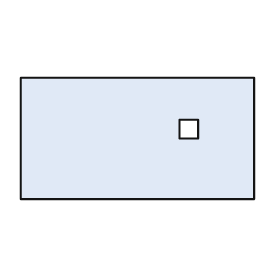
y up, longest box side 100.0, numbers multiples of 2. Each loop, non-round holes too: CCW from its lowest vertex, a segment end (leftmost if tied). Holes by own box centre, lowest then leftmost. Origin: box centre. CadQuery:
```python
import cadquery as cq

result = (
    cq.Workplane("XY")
    .moveTo(-50.0, -26.0)
    .lineTo(50.0, -26.0)
    .lineTo(50.0, 26.0)
    .lineTo(-50.0, 26.0)
    .close()
    .moveTo(18.0, 0.0)
    .lineTo(26.0, 0.0)
    .lineTo(26.0, 8.0)
    .lineTo(18.0, 8.0)
    .close()
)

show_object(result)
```